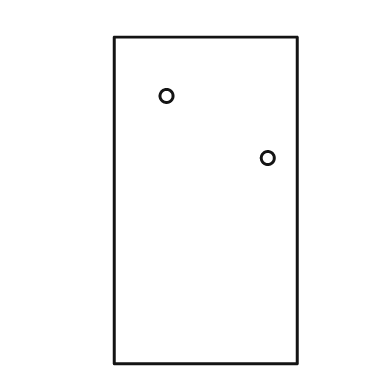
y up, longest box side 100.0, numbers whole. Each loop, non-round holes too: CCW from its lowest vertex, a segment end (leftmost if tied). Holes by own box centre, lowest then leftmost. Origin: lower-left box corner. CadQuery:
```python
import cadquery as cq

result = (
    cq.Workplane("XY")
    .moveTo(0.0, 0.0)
    .lineTo(56.0, 0.0)
    .lineTo(56.0, 100.0)
    .lineTo(0.0, 100.0)
    .close()
    .moveTo(47.0, 63.0)
    .circle(2.0)
    .moveTo(16.0, 82.0)
    .circle(2.0)
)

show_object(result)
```